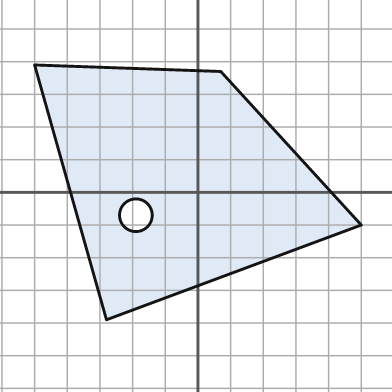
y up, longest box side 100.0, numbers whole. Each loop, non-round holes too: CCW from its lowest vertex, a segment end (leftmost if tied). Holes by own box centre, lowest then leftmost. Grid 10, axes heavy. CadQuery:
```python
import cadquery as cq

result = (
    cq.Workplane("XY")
    .moveTo(-28.0, -39.0)
    .lineTo(50.0, -10.0)
    .lineTo(7.0, 37.0)
    .lineTo(-50.0, 39.0)
    .close()
    .moveTo(-19.0, -7.0)
    .circle(5.0)
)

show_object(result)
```